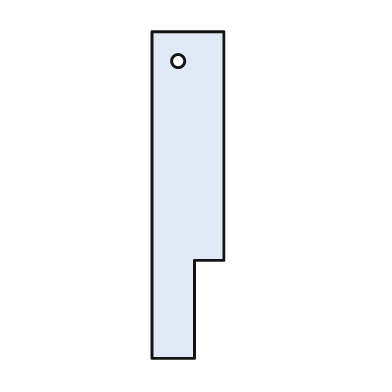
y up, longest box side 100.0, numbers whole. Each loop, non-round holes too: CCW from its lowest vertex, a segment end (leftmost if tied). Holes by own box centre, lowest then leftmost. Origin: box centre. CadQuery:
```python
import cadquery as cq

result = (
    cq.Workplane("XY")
    .moveTo(-11.0, -50.0)
    .lineTo(2.0, -50.0)
    .lineTo(2.0, -20.0)
    .lineTo(11.0, -20.0)
    .lineTo(11.0, 50.0)
    .lineTo(-11.0, 50.0)
    .close()
    .moveTo(-3.0, 41.0)
    .circle(2.0)
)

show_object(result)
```